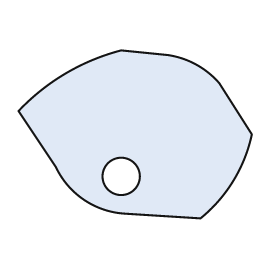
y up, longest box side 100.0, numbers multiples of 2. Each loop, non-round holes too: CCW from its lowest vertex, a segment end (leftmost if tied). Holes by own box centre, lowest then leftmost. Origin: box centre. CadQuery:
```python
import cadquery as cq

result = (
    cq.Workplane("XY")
    .moveTo(28.0, -36.0)
    .threePointArc((42.0, -20.0), (50.0, 0.0))
    .lineTo(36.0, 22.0)
    .threePointArc((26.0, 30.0), (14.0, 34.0))
    .lineTo(-6.0, 36.0)
    .threePointArc((-30.0, 26.0), (-50.0, 10.0))
    .lineTo(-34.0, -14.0)
    .threePointArc((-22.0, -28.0), (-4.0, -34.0))
    .close()
    .moveTo(-6.0, -18.0)
    .circle(8.0)
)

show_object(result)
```